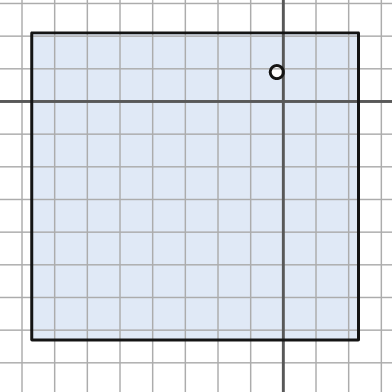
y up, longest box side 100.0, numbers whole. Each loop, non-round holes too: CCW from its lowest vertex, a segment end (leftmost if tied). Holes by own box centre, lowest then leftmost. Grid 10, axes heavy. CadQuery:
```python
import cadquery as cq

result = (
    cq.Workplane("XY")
    .moveTo(-77.0, -73.0)
    .lineTo(23.0, -73.0)
    .lineTo(23.0, 21.0)
    .lineTo(-77.0, 21.0)
    .close()
    .moveTo(-2.0, 9.0)
    .circle(2.0)
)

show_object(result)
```